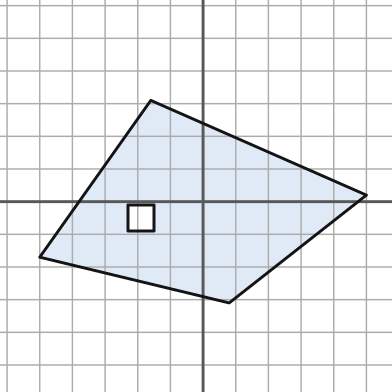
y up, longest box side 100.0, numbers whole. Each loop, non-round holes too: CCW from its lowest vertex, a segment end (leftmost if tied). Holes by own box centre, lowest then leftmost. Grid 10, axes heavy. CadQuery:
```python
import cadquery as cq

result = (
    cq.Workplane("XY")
    .moveTo(8.0, -31.0)
    .lineTo(50.0, 2.0)
    .lineTo(-16.0, 31.0)
    .lineTo(-50.0, -17.0)
    .close()
    .moveTo(-23.0, -9.0)
    .lineTo(-15.0, -9.0)
    .lineTo(-15.0, -1.0)
    .lineTo(-23.0, -1.0)
    .close()
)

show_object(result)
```